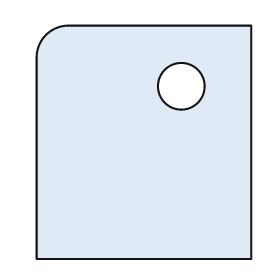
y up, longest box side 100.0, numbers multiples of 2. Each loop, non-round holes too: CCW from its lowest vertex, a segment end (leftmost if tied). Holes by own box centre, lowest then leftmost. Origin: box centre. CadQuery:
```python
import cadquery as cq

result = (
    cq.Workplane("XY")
    .moveTo(-46.0, -50.0)
    .lineTo(46.0, -50.0)
    .lineTo(46.0, 50.0)
    .lineTo(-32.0, 50.0)
    .threePointArc((-42.0, 46.0), (-46.0, 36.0))
    .close()
    .moveTo(16.0, 24.0)
    .circle(10.0)
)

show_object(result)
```